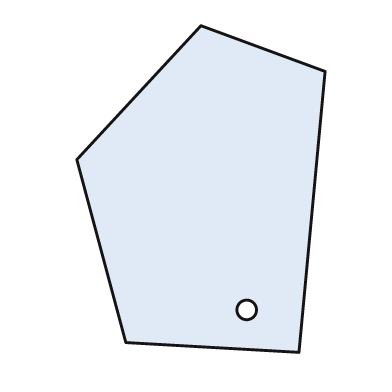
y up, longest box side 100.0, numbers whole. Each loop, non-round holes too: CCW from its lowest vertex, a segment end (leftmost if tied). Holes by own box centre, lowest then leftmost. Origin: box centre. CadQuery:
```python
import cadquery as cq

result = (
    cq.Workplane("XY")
    .moveTo(30.0, -50.0)
    .lineTo(38.0, 36.0)
    .lineTo(0.0, 50.0)
    .lineTo(-38.0, 9.0)
    .lineTo(-23.0, -47.0)
    .close()
    .moveTo(14.0, -37.0)
    .circle(3.0)
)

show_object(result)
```